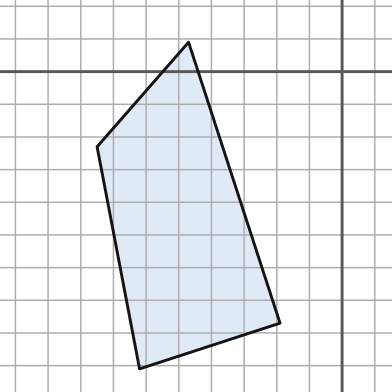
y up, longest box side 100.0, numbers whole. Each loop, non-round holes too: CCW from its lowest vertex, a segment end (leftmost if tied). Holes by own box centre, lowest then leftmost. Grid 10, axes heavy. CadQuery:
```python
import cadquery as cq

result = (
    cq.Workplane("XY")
    .moveTo(-62.0, -91.0)
    .lineTo(-19.0, -77.0)
    .lineTo(-47.0, 9.0)
    .lineTo(-75.0, -23.0)
    .close()
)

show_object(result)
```